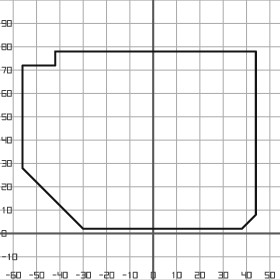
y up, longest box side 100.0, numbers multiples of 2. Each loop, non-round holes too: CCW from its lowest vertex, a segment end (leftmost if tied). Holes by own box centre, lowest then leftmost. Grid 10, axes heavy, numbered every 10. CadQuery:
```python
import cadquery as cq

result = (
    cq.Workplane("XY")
    .moveTo(-30.0, 2.0)
    .lineTo(38.0, 2.0)
    .lineTo(44.0, 8.0)
    .lineTo(44.0, 78.0)
    .lineTo(-42.0, 78.0)
    .lineTo(-42.0, 72.0)
    .lineTo(-56.0, 72.0)
    .lineTo(-56.0, 28.0)
    .close()
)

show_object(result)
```